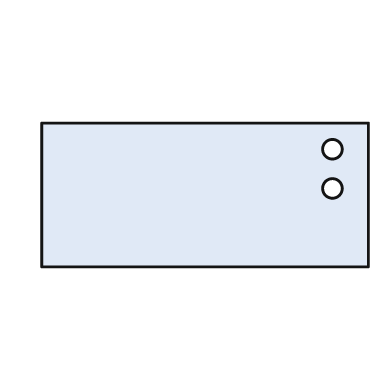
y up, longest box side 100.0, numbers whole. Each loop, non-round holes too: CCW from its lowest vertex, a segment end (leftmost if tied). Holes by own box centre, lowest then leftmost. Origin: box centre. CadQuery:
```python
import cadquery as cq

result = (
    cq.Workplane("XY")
    .moveTo(-50.0, -22.0)
    .lineTo(50.0, -22.0)
    .lineTo(50.0, 22.0)
    .lineTo(-50.0, 22.0)
    .close()
    .moveTo(39.0, 2.0)
    .circle(3.0)
    .moveTo(39.0, 14.0)
    .circle(3.0)
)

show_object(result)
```